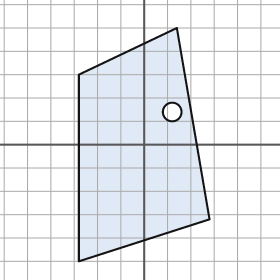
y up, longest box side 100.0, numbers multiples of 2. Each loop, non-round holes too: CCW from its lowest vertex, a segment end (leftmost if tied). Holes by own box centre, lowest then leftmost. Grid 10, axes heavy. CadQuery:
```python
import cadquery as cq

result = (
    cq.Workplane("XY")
    .moveTo(-28.0, -50.0)
    .lineTo(28.0, -32.0)
    .lineTo(14.0, 50.0)
    .lineTo(-28.0, 30.0)
    .close()
    .moveTo(12.0, 14.0)
    .circle(4.0)
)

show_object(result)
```